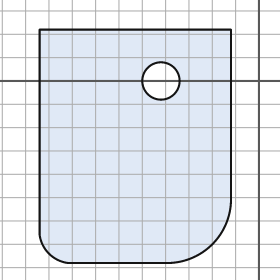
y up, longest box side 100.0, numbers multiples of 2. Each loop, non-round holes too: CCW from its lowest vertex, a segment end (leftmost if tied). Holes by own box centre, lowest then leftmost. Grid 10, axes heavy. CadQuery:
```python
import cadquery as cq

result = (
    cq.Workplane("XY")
    .moveTo(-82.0, -78.0)
    .lineTo(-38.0, -78.0)
    .threePointArc((-20.0, -70.0), (-12.0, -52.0))
    .lineTo(-12.0, 22.0)
    .lineTo(-94.0, 22.0)
    .lineTo(-94.0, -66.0)
    .threePointArc((-90.0, -74.0), (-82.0, -78.0))
    .close()
    .moveTo(-42.0, 0.0)
    .circle(8.0)
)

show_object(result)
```